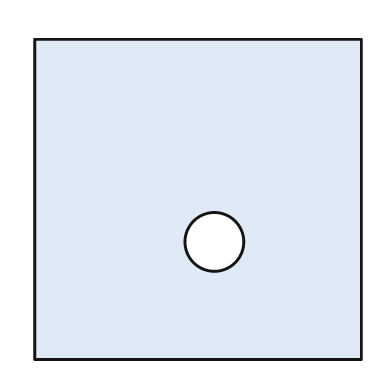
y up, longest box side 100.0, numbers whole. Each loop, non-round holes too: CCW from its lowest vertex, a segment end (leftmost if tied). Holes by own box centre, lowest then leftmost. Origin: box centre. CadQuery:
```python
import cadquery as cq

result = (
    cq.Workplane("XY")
    .moveTo(-50.0, -49.0)
    .lineTo(50.0, -49.0)
    .lineTo(50.0, 49.0)
    .lineTo(-50.0, 49.0)
    .close()
    .moveTo(5.0, -13.0)
    .circle(9.0)
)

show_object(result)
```